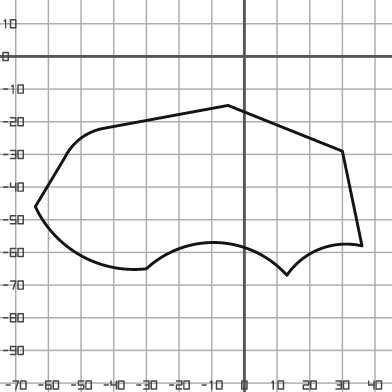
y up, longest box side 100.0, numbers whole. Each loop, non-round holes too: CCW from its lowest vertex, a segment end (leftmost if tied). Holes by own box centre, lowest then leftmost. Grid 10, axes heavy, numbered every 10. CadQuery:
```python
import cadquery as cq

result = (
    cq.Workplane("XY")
    .moveTo(13.0, -67.0)
    .threePointArc((23.0, -59.0), (36.0, -58.0))
    .lineTo(30.0, -29.0)
    .lineTo(-5.0, -15.0)
    .lineTo(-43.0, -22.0)
    .threePointArc((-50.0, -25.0), (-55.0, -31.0))
    .lineTo(-64.0, -46.0)
    .threePointArc((-50.0, -61.0), (-30.0, -65.0))
    .threePointArc((-8.0, -57.0), (13.0, -67.0))
    .close()
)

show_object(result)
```